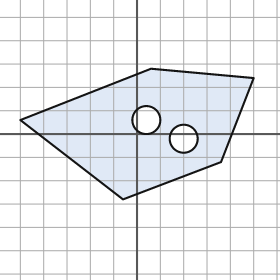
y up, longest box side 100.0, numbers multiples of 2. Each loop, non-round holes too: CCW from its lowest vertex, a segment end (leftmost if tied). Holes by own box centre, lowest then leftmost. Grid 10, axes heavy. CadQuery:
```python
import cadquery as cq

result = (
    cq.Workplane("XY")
    .moveTo(-6.0, -28.0)
    .lineTo(36.0, -12.0)
    .lineTo(50.0, 24.0)
    .lineTo(6.0, 28.0)
    .lineTo(-50.0, 6.0)
    .close()
    .moveTo(20.0, -2.0)
    .circle(6.0)
    .moveTo(4.0, 6.0)
    .circle(6.0)
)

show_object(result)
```